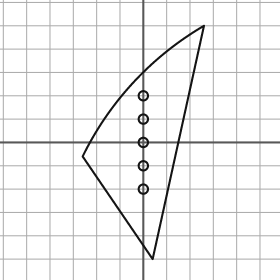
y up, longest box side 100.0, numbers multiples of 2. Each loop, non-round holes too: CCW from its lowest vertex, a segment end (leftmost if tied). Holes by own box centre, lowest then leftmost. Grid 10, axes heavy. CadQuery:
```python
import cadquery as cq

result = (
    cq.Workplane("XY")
    .moveTo(4.0, -50.0)
    .lineTo(26.0, 50.0)
    .threePointArc((-4.0, 26.0), (-26.0, -6.0))
    .close()
    .moveTo(0.0, -20.0)
    .circle(2.0)
    .moveTo(0.0, -10.0)
    .circle(2.0)
    .moveTo(0.0, 0.0)
    .circle(2.0)
    .moveTo(0.0, 10.0)
    .circle(2.0)
    .moveTo(0.0, 20.0)
    .circle(2.0)
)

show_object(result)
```